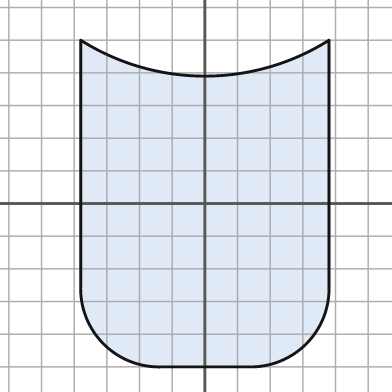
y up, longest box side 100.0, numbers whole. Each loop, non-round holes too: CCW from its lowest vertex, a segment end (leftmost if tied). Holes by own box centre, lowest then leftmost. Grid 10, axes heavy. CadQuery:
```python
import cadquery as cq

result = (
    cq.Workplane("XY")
    .moveTo(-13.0, -50.0)
    .lineTo(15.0, -50.0)
    .threePointArc((31.0, -43.0), (38.0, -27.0))
    .lineTo(38.0, 50.0)
    .threePointArc((0.0, 39.0), (-38.0, 50.0))
    .lineTo(-38.0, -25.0)
    .threePointArc((-31.0, -43.0), (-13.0, -50.0))
    .close()
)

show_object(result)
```